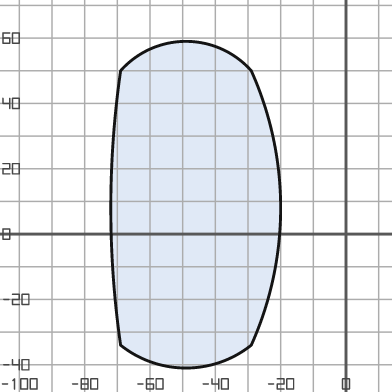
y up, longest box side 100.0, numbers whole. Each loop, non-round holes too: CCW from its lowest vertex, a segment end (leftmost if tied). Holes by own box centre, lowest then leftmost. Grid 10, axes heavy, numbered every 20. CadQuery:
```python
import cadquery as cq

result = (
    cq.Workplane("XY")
    .moveTo(-69.0, -34.0)
    .threePointArc((-49.0, -41.0), (-29.0, -34.0))
    .threePointArc((-20.0, 8.0), (-29.0, 50.0))
    .threePointArc((-49.0, 59.0), (-69.0, 50.0))
    .threePointArc((-72.0, 8.0), (-69.0, -34.0))
    .close()
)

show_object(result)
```